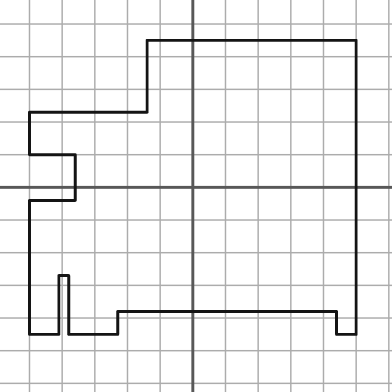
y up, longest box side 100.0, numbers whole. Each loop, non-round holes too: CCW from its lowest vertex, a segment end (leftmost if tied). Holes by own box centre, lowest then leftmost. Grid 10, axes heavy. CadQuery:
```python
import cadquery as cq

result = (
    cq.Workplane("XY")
    .moveTo(-50.0, -45.0)
    .lineTo(-41.0, -45.0)
    .lineTo(-41.0, -27.0)
    .lineTo(-38.0, -27.0)
    .lineTo(-38.0, -45.0)
    .lineTo(-23.0, -45.0)
    .lineTo(-23.0, -38.0)
    .lineTo(44.0, -38.0)
    .lineTo(44.0, -45.0)
    .lineTo(50.0, -45.0)
    .lineTo(50.0, 45.0)
    .lineTo(-14.0, 45.0)
    .lineTo(-14.0, 23.0)
    .lineTo(-50.0, 23.0)
    .lineTo(-50.0, 10.0)
    .lineTo(-36.0, 10.0)
    .lineTo(-36.0, -4.0)
    .lineTo(-50.0, -4.0)
    .close()
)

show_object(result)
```